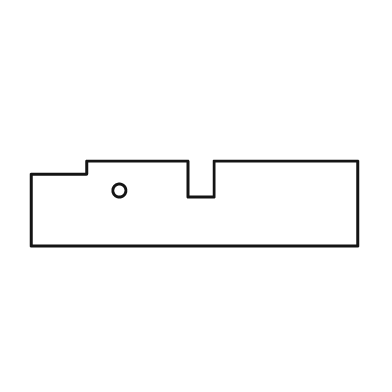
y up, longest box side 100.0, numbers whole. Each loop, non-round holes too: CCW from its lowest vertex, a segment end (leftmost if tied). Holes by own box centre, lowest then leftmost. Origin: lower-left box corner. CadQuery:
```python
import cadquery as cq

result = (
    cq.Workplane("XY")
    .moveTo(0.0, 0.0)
    .lineTo(100.0, 0.0)
    .lineTo(100.0, 26.0)
    .lineTo(56.0, 26.0)
    .lineTo(56.0, 15.0)
    .lineTo(48.0, 15.0)
    .lineTo(48.0, 26.0)
    .lineTo(17.0, 26.0)
    .lineTo(17.0, 22.0)
    .lineTo(0.0, 22.0)
    .close()
    .moveTo(27.0, 17.0)
    .circle(2.0)
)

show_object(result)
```